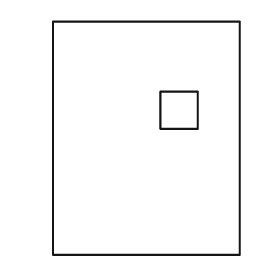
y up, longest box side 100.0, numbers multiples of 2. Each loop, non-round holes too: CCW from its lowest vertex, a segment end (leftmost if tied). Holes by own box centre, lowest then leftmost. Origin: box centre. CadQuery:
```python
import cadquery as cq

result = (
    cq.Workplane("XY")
    .moveTo(-40.0, -50.0)
    .lineTo(40.0, -50.0)
    .lineTo(40.0, 50.0)
    .lineTo(-40.0, 50.0)
    .close()
    .moveTo(6.0, 4.0)
    .lineTo(22.0, 4.0)
    .lineTo(22.0, 20.0)
    .lineTo(6.0, 20.0)
    .close()
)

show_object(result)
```